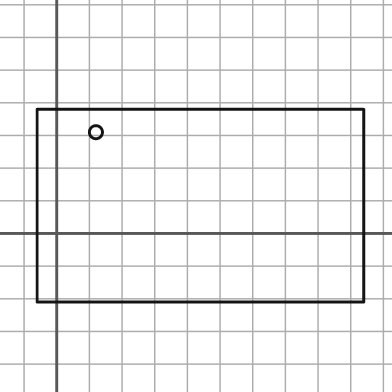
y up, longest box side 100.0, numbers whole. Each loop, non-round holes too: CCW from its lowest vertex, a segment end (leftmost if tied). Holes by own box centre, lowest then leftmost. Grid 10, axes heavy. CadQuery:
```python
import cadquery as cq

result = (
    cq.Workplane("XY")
    .moveTo(-6.0, -21.0)
    .lineTo(94.0, -21.0)
    .lineTo(94.0, 38.0)
    .lineTo(-6.0, 38.0)
    .close()
    .moveTo(12.0, 31.0)
    .circle(2.0)
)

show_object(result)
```